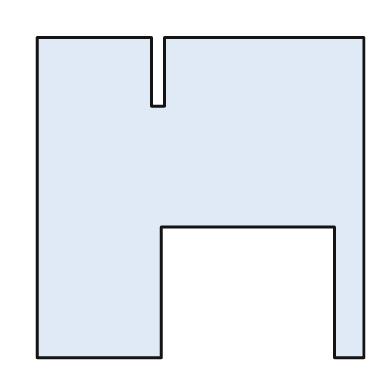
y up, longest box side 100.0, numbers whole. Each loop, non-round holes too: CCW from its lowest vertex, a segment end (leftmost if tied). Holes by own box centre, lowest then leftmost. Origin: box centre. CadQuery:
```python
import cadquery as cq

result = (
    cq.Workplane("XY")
    .moveTo(-50.0, -49.0)
    .lineTo(-12.0, -49.0)
    .lineTo(-12.0, -9.0)
    .lineTo(41.0, -9.0)
    .lineTo(41.0, -49.0)
    .lineTo(50.0, -49.0)
    .lineTo(50.0, 49.0)
    .lineTo(-11.0, 49.0)
    .lineTo(-11.0, 28.0)
    .lineTo(-15.0, 28.0)
    .lineTo(-15.0, 49.0)
    .lineTo(-50.0, 49.0)
    .close()
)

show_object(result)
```